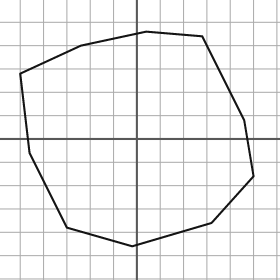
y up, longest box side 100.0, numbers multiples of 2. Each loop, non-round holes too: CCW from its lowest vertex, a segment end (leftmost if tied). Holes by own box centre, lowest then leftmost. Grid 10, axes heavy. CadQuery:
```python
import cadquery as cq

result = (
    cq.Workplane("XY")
    .moveTo(-2.0, -46.0)
    .lineTo(32.0, -36.0)
    .lineTo(50.0, -16.0)
    .lineTo(46.0, 8.0)
    .lineTo(28.0, 44.0)
    .lineTo(4.0, 46.0)
    .lineTo(-24.0, 40.0)
    .lineTo(-50.0, 28.0)
    .lineTo(-46.0, -6.0)
    .lineTo(-30.0, -38.0)
    .close()
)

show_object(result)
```